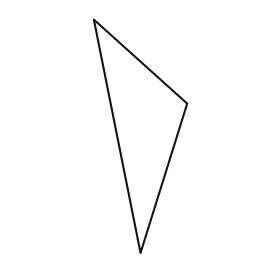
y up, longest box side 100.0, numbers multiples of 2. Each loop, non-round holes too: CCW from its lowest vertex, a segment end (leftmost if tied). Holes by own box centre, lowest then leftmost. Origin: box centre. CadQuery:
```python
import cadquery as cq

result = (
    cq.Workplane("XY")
    .moveTo(0.0, -50.0)
    .lineTo(20.0, 14.0)
    .lineTo(-20.0, 50.0)
    .close()
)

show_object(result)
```